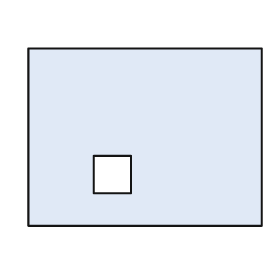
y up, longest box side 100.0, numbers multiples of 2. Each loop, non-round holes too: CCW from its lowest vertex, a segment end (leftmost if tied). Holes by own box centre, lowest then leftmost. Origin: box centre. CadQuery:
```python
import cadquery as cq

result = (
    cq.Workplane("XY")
    .moveTo(-50.0, -38.0)
    .lineTo(50.0, -38.0)
    .lineTo(50.0, 38.0)
    .lineTo(-50.0, 38.0)
    .close()
    .moveTo(-22.0, -24.0)
    .lineTo(-6.0, -24.0)
    .lineTo(-6.0, -8.0)
    .lineTo(-22.0, -8.0)
    .close()
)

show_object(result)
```